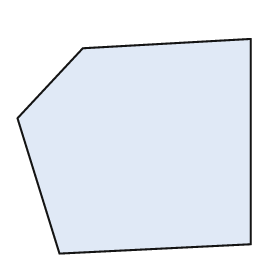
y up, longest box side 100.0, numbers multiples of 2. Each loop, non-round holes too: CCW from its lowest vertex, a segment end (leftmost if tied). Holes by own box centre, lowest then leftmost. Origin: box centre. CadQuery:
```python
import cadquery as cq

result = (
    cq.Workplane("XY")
    .moveTo(-32.0, -46.0)
    .lineTo(50.0, -42.0)
    .lineTo(50.0, 46.0)
    .lineTo(-22.0, 42.0)
    .lineTo(-50.0, 12.0)
    .close()
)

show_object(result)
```